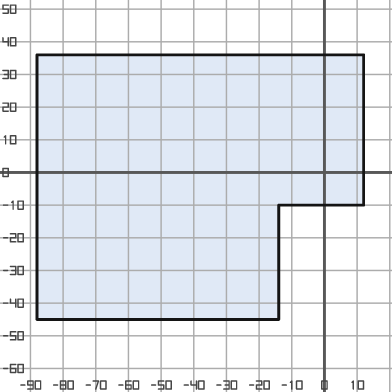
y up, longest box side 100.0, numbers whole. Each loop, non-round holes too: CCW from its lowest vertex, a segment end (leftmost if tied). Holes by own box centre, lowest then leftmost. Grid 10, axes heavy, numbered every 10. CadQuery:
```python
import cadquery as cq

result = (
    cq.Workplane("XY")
    .moveTo(-88.0, -45.0)
    .lineTo(-14.0, -45.0)
    .lineTo(-14.0, -10.0)
    .lineTo(12.0, -10.0)
    .lineTo(12.0, 36.0)
    .lineTo(-88.0, 36.0)
    .close()
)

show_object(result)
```